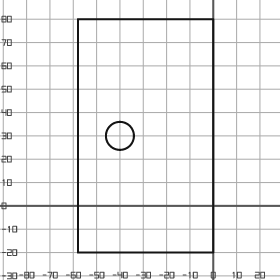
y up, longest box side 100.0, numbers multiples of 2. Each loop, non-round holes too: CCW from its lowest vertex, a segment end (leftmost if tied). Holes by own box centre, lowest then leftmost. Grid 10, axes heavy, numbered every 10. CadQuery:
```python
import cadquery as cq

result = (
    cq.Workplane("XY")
    .moveTo(-58.0, -20.0)
    .lineTo(0.0, -20.0)
    .lineTo(0.0, 80.0)
    .lineTo(-58.0, 80.0)
    .close()
    .moveTo(-40.0, 30.0)
    .circle(6.0)
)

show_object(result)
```